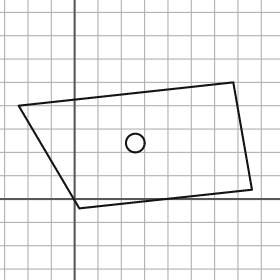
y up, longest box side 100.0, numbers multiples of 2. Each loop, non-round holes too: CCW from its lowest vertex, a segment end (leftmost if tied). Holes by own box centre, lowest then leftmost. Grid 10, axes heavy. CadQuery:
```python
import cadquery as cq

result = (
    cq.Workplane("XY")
    .moveTo(2.0, -4.0)
    .lineTo(76.0, 4.0)
    .lineTo(68.0, 50.0)
    .lineTo(-24.0, 40.0)
    .close()
    .moveTo(26.0, 24.0)
    .circle(4.0)
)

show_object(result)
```